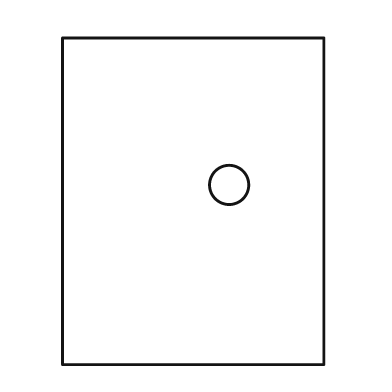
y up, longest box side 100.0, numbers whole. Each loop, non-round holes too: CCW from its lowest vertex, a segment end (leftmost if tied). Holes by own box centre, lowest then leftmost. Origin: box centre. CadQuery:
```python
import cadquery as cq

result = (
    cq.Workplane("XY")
    .moveTo(-40.0, -50.0)
    .lineTo(40.0, -50.0)
    .lineTo(40.0, 50.0)
    .lineTo(-40.0, 50.0)
    .close()
    .moveTo(11.0, 5.0)
    .circle(6.0)
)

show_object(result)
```